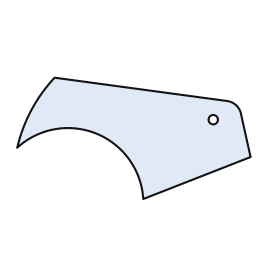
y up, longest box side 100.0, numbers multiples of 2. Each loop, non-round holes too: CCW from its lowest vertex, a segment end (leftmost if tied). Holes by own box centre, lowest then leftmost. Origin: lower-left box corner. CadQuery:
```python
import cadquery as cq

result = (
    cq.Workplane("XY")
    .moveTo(54.0, 0.0)
    .lineTo(100.0, 18.0)
    .lineTo(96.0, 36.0)
    .threePointArc((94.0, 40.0), (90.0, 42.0))
    .lineTo(16.0, 52.0)
    .threePointArc((6.0, 38.0), (0.0, 22.0))
    .threePointArc((34.0, 28.0), (54.0, 0.0))
    .close()
    .moveTo(84.0, 34.0)
    .circle(2.0)
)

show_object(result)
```